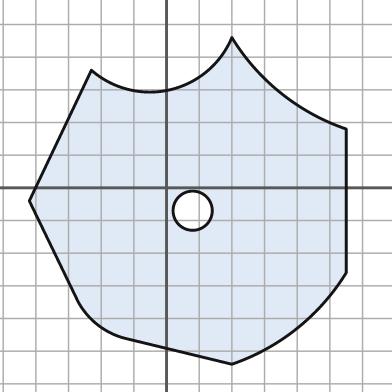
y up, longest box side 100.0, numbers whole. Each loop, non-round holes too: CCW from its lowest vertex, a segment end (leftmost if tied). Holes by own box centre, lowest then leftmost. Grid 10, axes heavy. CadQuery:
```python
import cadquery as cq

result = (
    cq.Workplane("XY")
    .moveTo(20.0, -54.0)
    .threePointArc((40.0, -43.0), (55.0, -26.0))
    .lineTo(55.0, 18.0)
    .threePointArc((35.0, 29.0), (20.0, 46.0))
    .threePointArc((1.0, 30.0), (-23.0, 36.0))
    .lineTo(-42.0, -4.0)
    .lineTo(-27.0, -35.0)
    .threePointArc((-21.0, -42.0), (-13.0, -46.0))
    .close()
    .moveTo(8.0, -7.0)
    .circle(6.0)
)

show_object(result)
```